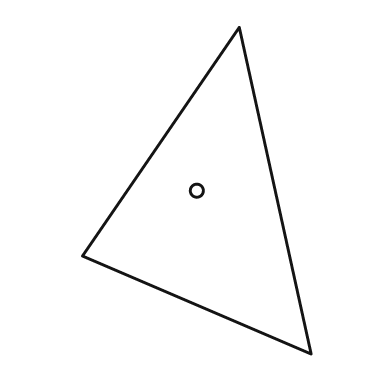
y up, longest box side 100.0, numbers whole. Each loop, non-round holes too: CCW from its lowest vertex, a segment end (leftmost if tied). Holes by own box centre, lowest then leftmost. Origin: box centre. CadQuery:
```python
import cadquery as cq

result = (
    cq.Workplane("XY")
    .moveTo(35.0, -50.0)
    .lineTo(13.0, 50.0)
    .lineTo(-35.0, -20.0)
    .close()
    .moveTo(0.0, 0.0)
    .circle(2.0)
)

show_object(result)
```